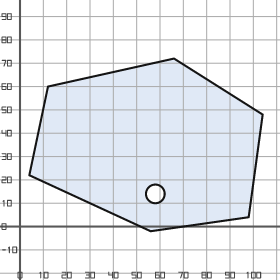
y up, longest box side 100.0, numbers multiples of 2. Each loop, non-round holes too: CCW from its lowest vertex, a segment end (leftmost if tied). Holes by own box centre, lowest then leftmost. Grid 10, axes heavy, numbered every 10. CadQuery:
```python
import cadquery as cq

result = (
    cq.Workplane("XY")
    .moveTo(56.0, -2.0)
    .lineTo(98.0, 4.0)
    .lineTo(104.0, 48.0)
    .lineTo(66.0, 72.0)
    .lineTo(12.0, 60.0)
    .lineTo(4.0, 22.0)
    .close()
    .moveTo(58.0, 14.0)
    .circle(4.0)
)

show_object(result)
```